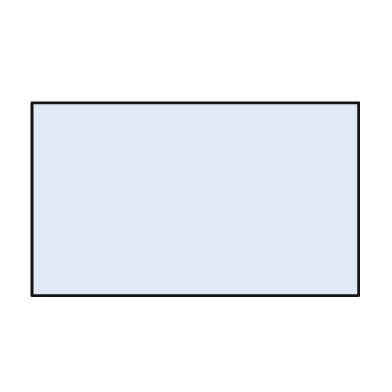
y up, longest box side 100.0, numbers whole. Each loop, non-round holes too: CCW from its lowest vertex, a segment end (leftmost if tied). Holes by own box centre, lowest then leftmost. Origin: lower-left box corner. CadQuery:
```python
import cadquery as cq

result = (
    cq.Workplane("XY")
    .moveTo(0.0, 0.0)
    .lineTo(100.0, 0.0)
    .lineTo(100.0, 59.0)
    .lineTo(0.0, 59.0)
    .close()
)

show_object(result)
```